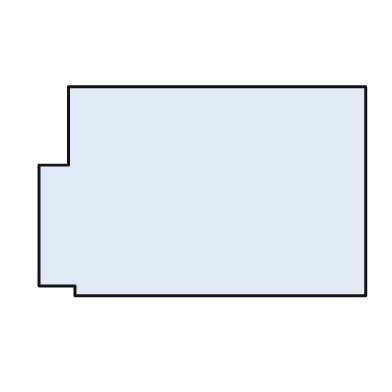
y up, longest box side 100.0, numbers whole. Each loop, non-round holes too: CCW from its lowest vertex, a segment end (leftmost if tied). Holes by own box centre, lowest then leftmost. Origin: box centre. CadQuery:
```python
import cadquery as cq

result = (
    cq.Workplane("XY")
    .moveTo(-39.0, -32.0)
    .lineTo(50.0, -32.0)
    .lineTo(50.0, 32.0)
    .lineTo(-41.0, 32.0)
    .lineTo(-41.0, 8.0)
    .lineTo(-50.0, 8.0)
    .lineTo(-50.0, -29.0)
    .lineTo(-39.0, -29.0)
    .close()
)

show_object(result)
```